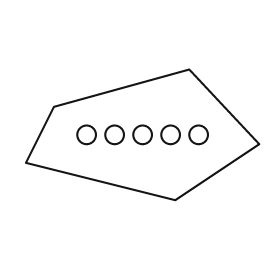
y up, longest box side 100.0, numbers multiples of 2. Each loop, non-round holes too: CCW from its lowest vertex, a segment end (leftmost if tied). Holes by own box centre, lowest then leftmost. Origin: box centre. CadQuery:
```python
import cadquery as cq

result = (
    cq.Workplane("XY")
    .moveTo(14.0, -28.0)
    .lineTo(50.0, -4.0)
    .lineTo(20.0, 28.0)
    .lineTo(-38.0, 12.0)
    .lineTo(-50.0, -12.0)
    .close()
    .moveTo(-24.0, 0.0)
    .circle(4.0)
    .moveTo(-12.0, 0.0)
    .circle(4.0)
    .moveTo(0.0, 0.0)
    .circle(4.0)
    .moveTo(12.0, 0.0)
    .circle(4.0)
    .moveTo(24.0, 0.0)
    .circle(4.0)
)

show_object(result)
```